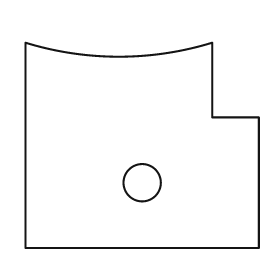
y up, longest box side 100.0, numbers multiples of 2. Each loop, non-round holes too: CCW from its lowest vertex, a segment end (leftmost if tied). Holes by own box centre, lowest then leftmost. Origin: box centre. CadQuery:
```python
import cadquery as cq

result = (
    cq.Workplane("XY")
    .moveTo(-50.0, -44.0)
    .lineTo(50.0, -44.0)
    .lineTo(50.0, 12.0)
    .lineTo(30.0, 12.0)
    .lineTo(30.0, 44.0)
    .threePointArc((-10.0, 38.0), (-50.0, 44.0))
    .close()
    .moveTo(0.0, -16.0)
    .circle(8.0)
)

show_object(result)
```